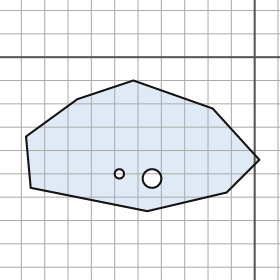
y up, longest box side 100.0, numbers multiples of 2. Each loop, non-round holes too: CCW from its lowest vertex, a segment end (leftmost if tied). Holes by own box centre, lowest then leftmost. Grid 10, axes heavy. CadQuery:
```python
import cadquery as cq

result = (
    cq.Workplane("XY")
    .moveTo(-46.0, -66.0)
    .lineTo(-12.0, -58.0)
    .lineTo(2.0, -44.0)
    .lineTo(-18.0, -22.0)
    .lineTo(-52.0, -10.0)
    .lineTo(-76.0, -18.0)
    .lineTo(-98.0, -34.0)
    .lineTo(-96.0, -56.0)
    .close()
    .moveTo(-44.0, -52.0)
    .circle(4.0)
    .moveTo(-58.0, -50.0)
    .circle(2.0)
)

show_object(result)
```